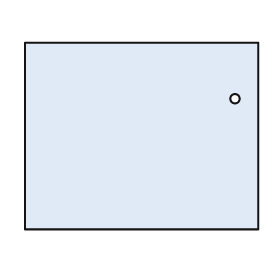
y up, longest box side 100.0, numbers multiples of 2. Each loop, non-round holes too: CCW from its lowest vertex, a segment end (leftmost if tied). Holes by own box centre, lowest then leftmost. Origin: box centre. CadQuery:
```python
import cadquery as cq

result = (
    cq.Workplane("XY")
    .moveTo(-50.0, -40.0)
    .lineTo(50.0, -40.0)
    .lineTo(50.0, 40.0)
    .lineTo(-50.0, 40.0)
    .close()
    .moveTo(40.0, 16.0)
    .circle(2.0)
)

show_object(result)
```